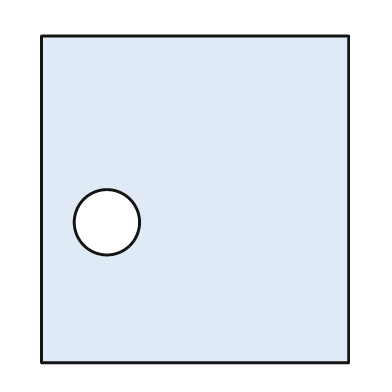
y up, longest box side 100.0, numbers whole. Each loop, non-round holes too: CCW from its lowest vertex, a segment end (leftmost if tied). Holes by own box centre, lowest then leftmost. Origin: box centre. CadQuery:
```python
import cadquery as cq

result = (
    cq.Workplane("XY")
    .moveTo(-47.0, -50.0)
    .lineTo(47.0, -50.0)
    .lineTo(47.0, 50.0)
    .lineTo(-47.0, 50.0)
    .close()
    .moveTo(-27.0, -7.0)
    .circle(10.0)
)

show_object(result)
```